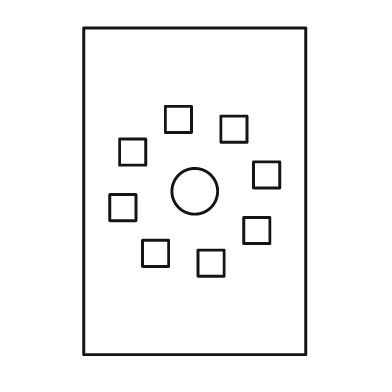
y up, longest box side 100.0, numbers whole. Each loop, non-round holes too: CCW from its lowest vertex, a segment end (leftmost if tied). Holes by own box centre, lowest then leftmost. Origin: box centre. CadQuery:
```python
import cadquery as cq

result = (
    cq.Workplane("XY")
    .moveTo(-34.0, -50.0)
    .lineTo(34.0, -50.0)
    .lineTo(34.0, 50.0)
    .lineTo(-34.0, 50.0)
    .close()
    .moveTo(1.0, -26.0)
    .lineTo(9.0, -26.0)
    .lineTo(9.0, -18.0)
    .lineTo(1.0, -18.0)
    .close()
    .moveTo(-16.0, -23.0)
    .lineTo(-8.0, -23.0)
    .lineTo(-8.0, -15.0)
    .lineTo(-16.0, -15.0)
    .close()
    .moveTo(15.0, -16.0)
    .lineTo(23.0, -16.0)
    .lineTo(23.0, -8.0)
    .lineTo(15.0, -8.0)
    .close()
    .moveTo(-26.0, -9.0)
    .lineTo(-18.0, -9.0)
    .lineTo(-18.0, -1.0)
    .lineTo(-26.0, -1.0)
    .close()
    .moveTo(0.0, 0.0)
    .circle(7.0)
    .moveTo(18.0, 1.0)
    .lineTo(26.0, 1.0)
    .lineTo(26.0, 9.0)
    .lineTo(18.0, 9.0)
    .close()
    .moveTo(-23.0, 8.0)
    .lineTo(-15.0, 8.0)
    .lineTo(-15.0, 16.0)
    .lineTo(-23.0, 16.0)
    .close()
    .moveTo(8.0, 15.0)
    .lineTo(16.0, 15.0)
    .lineTo(16.0, 23.0)
    .lineTo(8.0, 23.0)
    .close()
    .moveTo(-9.0, 18.0)
    .lineTo(-1.0, 18.0)
    .lineTo(-1.0, 26.0)
    .lineTo(-9.0, 26.0)
    .close()
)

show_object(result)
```